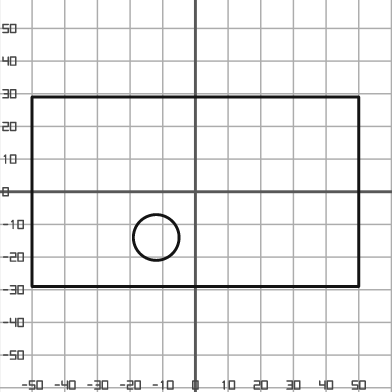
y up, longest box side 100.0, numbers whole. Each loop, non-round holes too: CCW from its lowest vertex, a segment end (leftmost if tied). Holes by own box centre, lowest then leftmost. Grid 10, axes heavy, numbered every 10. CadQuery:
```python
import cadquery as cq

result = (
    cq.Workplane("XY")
    .moveTo(-50.0, -29.0)
    .lineTo(50.0, -29.0)
    .lineTo(50.0, 29.0)
    .lineTo(-50.0, 29.0)
    .close()
    .moveTo(-12.0, -14.0)
    .circle(7.0)
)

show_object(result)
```